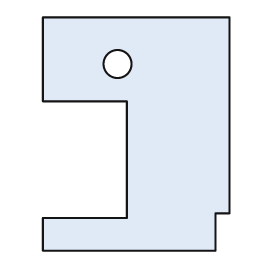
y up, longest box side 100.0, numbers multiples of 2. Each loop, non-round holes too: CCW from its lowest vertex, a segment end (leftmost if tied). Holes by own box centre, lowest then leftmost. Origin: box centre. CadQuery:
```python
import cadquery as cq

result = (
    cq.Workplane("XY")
    .moveTo(-40.0, -50.0)
    .lineTo(34.0, -50.0)
    .lineTo(34.0, -34.0)
    .lineTo(40.0, -34.0)
    .lineTo(40.0, 50.0)
    .lineTo(-40.0, 50.0)
    .lineTo(-40.0, 14.0)
    .lineTo(-4.0, 14.0)
    .lineTo(-4.0, -36.0)
    .lineTo(-40.0, -36.0)
    .close()
    .moveTo(-8.0, 30.0)
    .circle(6.0)
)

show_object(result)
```